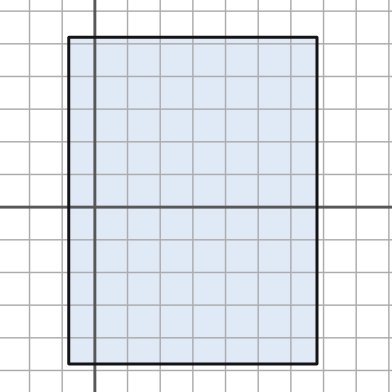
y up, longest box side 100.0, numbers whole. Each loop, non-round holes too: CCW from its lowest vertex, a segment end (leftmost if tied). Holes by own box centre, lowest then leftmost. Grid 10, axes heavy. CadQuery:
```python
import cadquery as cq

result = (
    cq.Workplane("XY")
    .moveTo(-8.0, -48.0)
    .lineTo(68.0, -48.0)
    .lineTo(68.0, 52.0)
    .lineTo(-8.0, 52.0)
    .close()
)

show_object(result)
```